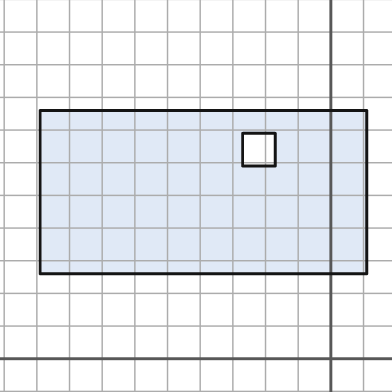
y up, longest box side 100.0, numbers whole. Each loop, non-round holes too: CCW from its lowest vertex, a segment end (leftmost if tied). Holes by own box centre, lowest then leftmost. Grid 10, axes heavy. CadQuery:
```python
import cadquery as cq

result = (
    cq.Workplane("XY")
    .moveTo(-89.0, 26.0)
    .lineTo(11.0, 26.0)
    .lineTo(11.0, 76.0)
    .lineTo(-89.0, 76.0)
    .close()
    .moveTo(-27.0, 59.0)
    .lineTo(-17.0, 59.0)
    .lineTo(-17.0, 69.0)
    .lineTo(-27.0, 69.0)
    .close()
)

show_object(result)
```